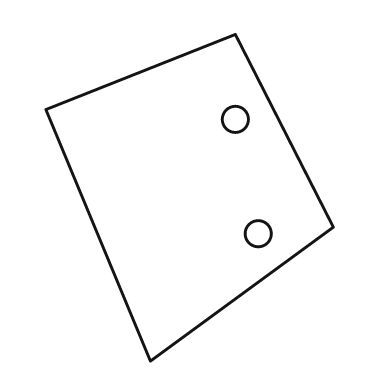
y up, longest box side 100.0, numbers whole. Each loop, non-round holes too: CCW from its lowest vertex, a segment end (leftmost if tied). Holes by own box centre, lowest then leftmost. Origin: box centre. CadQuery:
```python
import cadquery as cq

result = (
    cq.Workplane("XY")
    .moveTo(-12.0, -50.0)
    .lineTo(44.0, -9.0)
    .lineTo(14.0, 50.0)
    .lineTo(-44.0, 27.0)
    .close()
    .moveTo(21.0, -11.0)
    .circle(4.0)
    .moveTo(14.0, 24.0)
    .circle(4.0)
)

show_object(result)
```